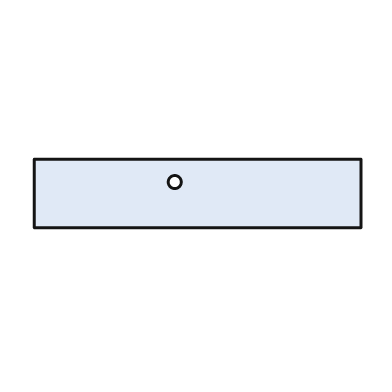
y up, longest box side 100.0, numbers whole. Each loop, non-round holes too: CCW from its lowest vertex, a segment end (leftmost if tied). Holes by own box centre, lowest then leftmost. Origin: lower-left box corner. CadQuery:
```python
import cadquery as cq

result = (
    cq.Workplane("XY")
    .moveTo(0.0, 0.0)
    .lineTo(100.0, 0.0)
    .lineTo(100.0, 21.0)
    .lineTo(0.0, 21.0)
    .close()
    .moveTo(43.0, 14.0)
    .circle(2.0)
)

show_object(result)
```